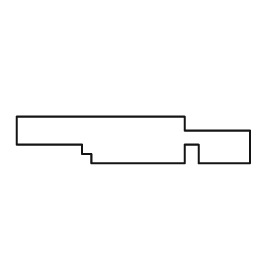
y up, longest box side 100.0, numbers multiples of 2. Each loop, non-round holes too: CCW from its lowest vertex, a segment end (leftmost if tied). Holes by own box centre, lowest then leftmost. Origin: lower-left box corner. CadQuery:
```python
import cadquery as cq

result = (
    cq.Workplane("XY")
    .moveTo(32.0, 0.0)
    .lineTo(72.0, 0.0)
    .lineTo(72.0, 8.0)
    .lineTo(78.0, 8.0)
    .lineTo(78.0, 0.0)
    .lineTo(100.0, 0.0)
    .lineTo(100.0, 14.0)
    .lineTo(72.0, 14.0)
    .lineTo(72.0, 20.0)
    .lineTo(0.0, 20.0)
    .lineTo(0.0, 8.0)
    .lineTo(28.0, 8.0)
    .lineTo(28.0, 4.0)
    .lineTo(32.0, 4.0)
    .close()
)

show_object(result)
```